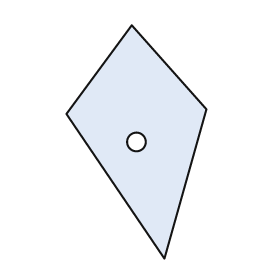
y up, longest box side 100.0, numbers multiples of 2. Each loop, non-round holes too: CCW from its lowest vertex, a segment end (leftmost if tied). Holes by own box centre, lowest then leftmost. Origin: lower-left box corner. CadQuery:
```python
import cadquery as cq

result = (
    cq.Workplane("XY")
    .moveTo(42.0, 0.0)
    .lineTo(60.0, 64.0)
    .lineTo(28.0, 100.0)
    .lineTo(0.0, 62.0)
    .close()
    .moveTo(30.0, 50.0)
    .circle(4.0)
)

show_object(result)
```